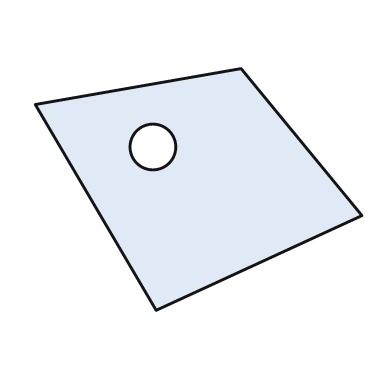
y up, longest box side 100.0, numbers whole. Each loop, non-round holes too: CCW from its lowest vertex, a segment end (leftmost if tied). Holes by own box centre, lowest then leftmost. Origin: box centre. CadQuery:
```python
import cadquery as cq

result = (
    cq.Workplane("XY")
    .moveTo(-13.0, -37.0)
    .lineTo(50.0, -8.0)
    .lineTo(13.0, 37.0)
    .lineTo(-50.0, 26.0)
    .close()
    .moveTo(-14.0, 13.0)
    .circle(7.0)
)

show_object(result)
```